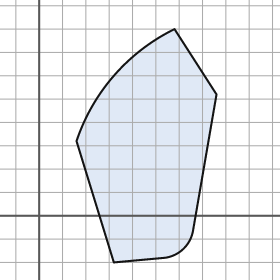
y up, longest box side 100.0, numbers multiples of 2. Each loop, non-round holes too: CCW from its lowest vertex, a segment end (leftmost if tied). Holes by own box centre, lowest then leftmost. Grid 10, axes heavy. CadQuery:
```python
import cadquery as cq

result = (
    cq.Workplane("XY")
    .moveTo(32.0, -20.0)
    .lineTo(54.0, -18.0)
    .threePointArc((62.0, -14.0), (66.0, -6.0))
    .lineTo(76.0, 52.0)
    .lineTo(58.0, 80.0)
    .threePointArc((32.0, 60.0), (16.0, 32.0))
    .close()
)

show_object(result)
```